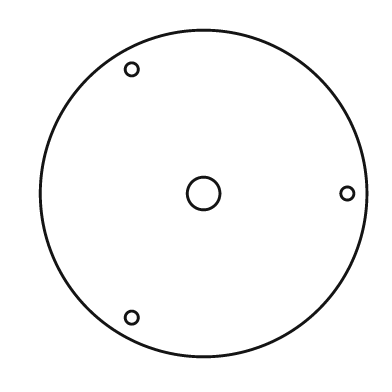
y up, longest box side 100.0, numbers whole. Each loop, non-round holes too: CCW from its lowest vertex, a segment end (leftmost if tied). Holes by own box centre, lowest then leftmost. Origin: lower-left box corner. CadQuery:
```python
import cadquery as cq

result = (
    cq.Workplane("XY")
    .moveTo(50.0, 50.0)
    .circle(50.0)
    .moveTo(28.0, 12.0)
    .circle(2.0)
    .moveTo(50.0, 50.0)
    .circle(5.0)
    .moveTo(94.0, 50.0)
    .circle(2.0)
    .moveTo(28.0, 88.0)
    .circle(2.0)
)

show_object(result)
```